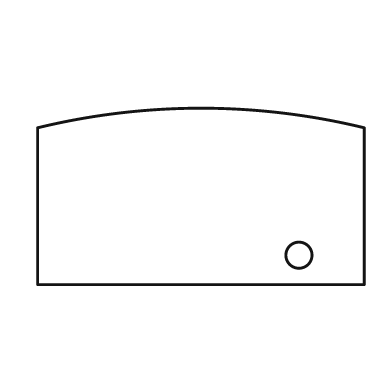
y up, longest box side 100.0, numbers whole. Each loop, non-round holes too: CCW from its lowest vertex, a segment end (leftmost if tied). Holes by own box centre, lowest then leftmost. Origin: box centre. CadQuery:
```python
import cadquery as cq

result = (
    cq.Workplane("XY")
    .moveTo(-50.0, -27.0)
    .lineTo(50.0, -27.0)
    .lineTo(50.0, 21.0)
    .threePointArc((0.0, 27.0), (-50.0, 21.0))
    .close()
    .moveTo(30.0, -18.0)
    .circle(4.0)
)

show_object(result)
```